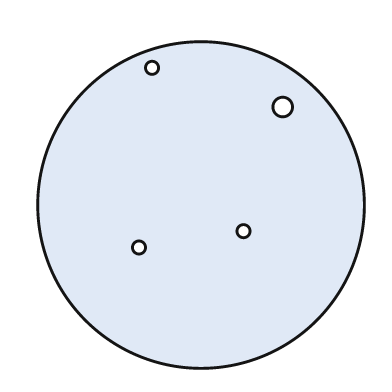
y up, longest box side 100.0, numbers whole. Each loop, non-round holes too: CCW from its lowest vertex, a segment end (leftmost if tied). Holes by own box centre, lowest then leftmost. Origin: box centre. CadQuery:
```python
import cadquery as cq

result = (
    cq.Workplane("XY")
    .moveTo(0.0, 0.0)
    .circle(50.0)
    .moveTo(-19.0, -13.0)
    .circle(2.0)
    .moveTo(13.0, -8.0)
    .circle(2.0)
    .moveTo(25.0, 30.0)
    .circle(3.0)
    .moveTo(-15.0, 42.0)
    .circle(2.0)
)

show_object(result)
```